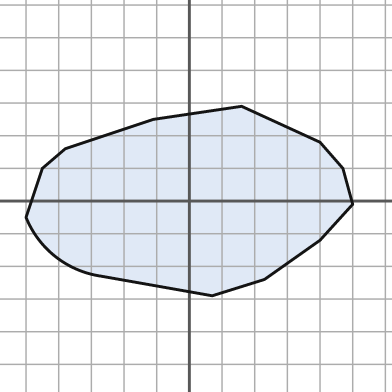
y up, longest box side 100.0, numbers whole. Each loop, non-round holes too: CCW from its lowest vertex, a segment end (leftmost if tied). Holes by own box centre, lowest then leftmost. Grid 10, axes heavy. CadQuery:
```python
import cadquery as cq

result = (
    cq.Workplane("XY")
    .moveTo(7.0, -29.0)
    .lineTo(23.0, -24.0)
    .lineTo(40.0, -12.0)
    .lineTo(50.0, -1.0)
    .lineTo(47.0, 10.0)
    .lineTo(40.0, 18.0)
    .lineTo(16.0, 29.0)
    .lineTo(-11.0, 25.0)
    .lineTo(-38.0, 16.0)
    .lineTo(-45.0, 10.0)
    .lineTo(-50.0, -5.0)
    .threePointArc((-41.0, -17.0), (-27.0, -23.0))
    .close()
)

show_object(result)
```